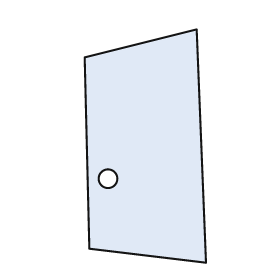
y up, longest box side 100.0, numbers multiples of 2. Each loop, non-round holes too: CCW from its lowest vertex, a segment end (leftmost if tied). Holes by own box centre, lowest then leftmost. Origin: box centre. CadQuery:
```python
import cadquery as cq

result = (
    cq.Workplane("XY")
    .moveTo(26.0, -50.0)
    .lineTo(22.0, 50.0)
    .lineTo(-26.0, 38.0)
    .lineTo(-24.0, -44.0)
    .close()
    .moveTo(-16.0, -14.0)
    .circle(4.0)
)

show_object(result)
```